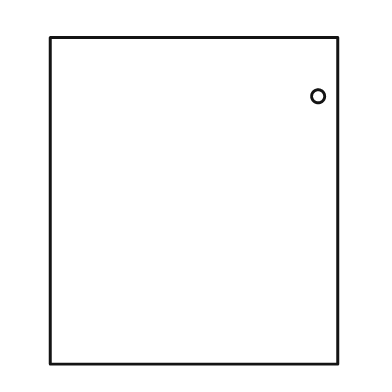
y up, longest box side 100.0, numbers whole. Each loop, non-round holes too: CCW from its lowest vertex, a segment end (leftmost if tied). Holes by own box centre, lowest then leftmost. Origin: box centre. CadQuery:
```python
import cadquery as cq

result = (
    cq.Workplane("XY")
    .moveTo(-44.0, -50.0)
    .lineTo(44.0, -50.0)
    .lineTo(44.0, 50.0)
    .lineTo(-44.0, 50.0)
    .close()
    .moveTo(38.0, 32.0)
    .circle(2.0)
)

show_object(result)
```